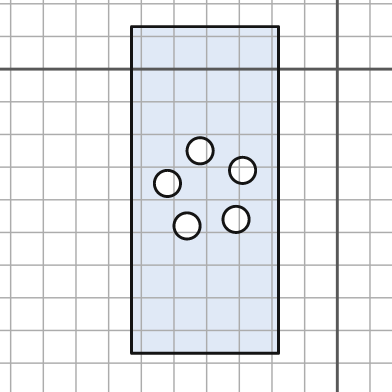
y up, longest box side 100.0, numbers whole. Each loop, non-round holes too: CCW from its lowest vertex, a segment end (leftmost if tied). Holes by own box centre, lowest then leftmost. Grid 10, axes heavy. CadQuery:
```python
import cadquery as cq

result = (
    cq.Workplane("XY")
    .moveTo(-63.0, -87.0)
    .lineTo(-18.0, -87.0)
    .lineTo(-18.0, 13.0)
    .lineTo(-63.0, 13.0)
    .close()
    .moveTo(-46.0, -48.0)
    .circle(4.0)
    .moveTo(-31.0, -46.0)
    .circle(4.0)
    .moveTo(-52.0, -35.0)
    .circle(4.0)
    .moveTo(-29.0, -31.0)
    .circle(4.0)
    .moveTo(-42.0, -25.0)
    .circle(4.0)
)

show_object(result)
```